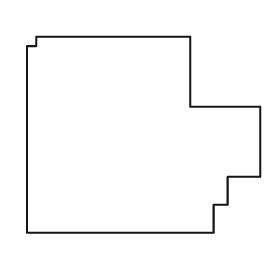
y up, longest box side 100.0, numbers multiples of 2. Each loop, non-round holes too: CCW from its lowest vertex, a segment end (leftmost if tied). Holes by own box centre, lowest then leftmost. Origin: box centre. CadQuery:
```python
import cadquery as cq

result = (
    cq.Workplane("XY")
    .moveTo(-50.0, -42.0)
    .lineTo(30.0, -42.0)
    .lineTo(30.0, -30.0)
    .lineTo(36.0, -30.0)
    .lineTo(36.0, -18.0)
    .lineTo(50.0, -18.0)
    .lineTo(50.0, 12.0)
    .lineTo(20.0, 12.0)
    .lineTo(20.0, 42.0)
    .lineTo(-46.0, 42.0)
    .lineTo(-46.0, 38.0)
    .lineTo(-50.0, 38.0)
    .close()
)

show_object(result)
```